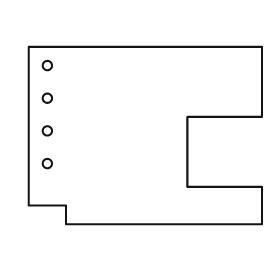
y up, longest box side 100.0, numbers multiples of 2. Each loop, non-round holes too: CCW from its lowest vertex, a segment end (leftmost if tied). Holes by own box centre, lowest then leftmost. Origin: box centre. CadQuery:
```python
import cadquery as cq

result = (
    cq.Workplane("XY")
    .moveTo(-34.0, -38.0)
    .lineTo(50.0, -38.0)
    .lineTo(50.0, -22.0)
    .lineTo(18.0, -22.0)
    .lineTo(18.0, 8.0)
    .lineTo(50.0, 8.0)
    .lineTo(50.0, 38.0)
    .lineTo(-50.0, 38.0)
    .lineTo(-50.0, -30.0)
    .lineTo(-34.0, -30.0)
    .close()
    .moveTo(-42.0, -12.0)
    .circle(2.0)
    .moveTo(-42.0, 2.0)
    .circle(2.0)
    .moveTo(-42.0, 16.0)
    .circle(2.0)
    .moveTo(-42.0, 30.0)
    .circle(2.0)
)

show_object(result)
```